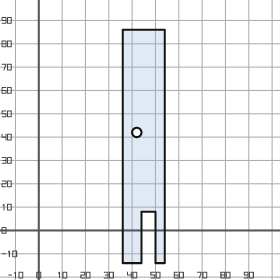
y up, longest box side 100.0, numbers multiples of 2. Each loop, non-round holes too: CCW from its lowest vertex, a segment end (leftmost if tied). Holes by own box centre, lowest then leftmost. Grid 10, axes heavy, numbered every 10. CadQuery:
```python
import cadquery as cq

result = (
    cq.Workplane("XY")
    .moveTo(36.0, -14.0)
    .lineTo(44.0, -14.0)
    .lineTo(44.0, 8.0)
    .lineTo(50.0, 8.0)
    .lineTo(50.0, -14.0)
    .lineTo(54.0, -14.0)
    .lineTo(54.0, 86.0)
    .lineTo(36.0, 86.0)
    .close()
    .moveTo(42.0, 42.0)
    .circle(2.0)
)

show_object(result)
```